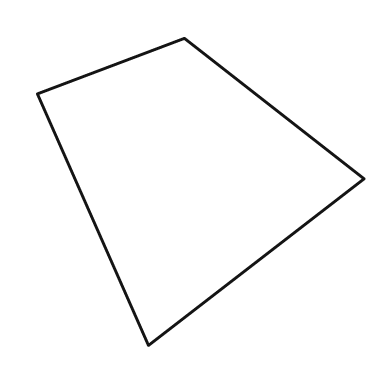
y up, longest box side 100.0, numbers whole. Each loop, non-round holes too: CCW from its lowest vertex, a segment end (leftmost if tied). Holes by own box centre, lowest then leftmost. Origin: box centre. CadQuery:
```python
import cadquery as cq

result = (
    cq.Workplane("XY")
    .moveTo(-16.0, -47.0)
    .lineTo(50.0, 4.0)
    .lineTo(-5.0, 47.0)
    .lineTo(-50.0, 30.0)
    .close()
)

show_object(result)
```